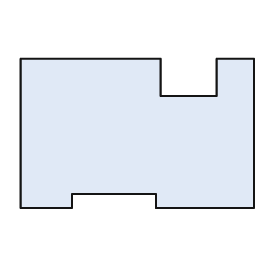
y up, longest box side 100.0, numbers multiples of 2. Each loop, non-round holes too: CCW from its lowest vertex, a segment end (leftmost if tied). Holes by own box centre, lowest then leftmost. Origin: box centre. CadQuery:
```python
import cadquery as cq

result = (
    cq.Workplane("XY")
    .moveTo(-50.0, -32.0)
    .lineTo(-28.0, -32.0)
    .lineTo(-28.0, -26.0)
    .lineTo(8.0, -26.0)
    .lineTo(8.0, -32.0)
    .lineTo(50.0, -32.0)
    .lineTo(50.0, 32.0)
    .lineTo(34.0, 32.0)
    .lineTo(34.0, 16.0)
    .lineTo(10.0, 16.0)
    .lineTo(10.0, 32.0)
    .lineTo(-50.0, 32.0)
    .close()
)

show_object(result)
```